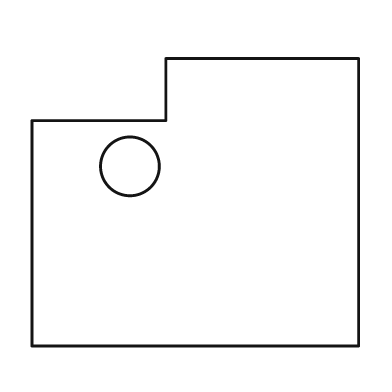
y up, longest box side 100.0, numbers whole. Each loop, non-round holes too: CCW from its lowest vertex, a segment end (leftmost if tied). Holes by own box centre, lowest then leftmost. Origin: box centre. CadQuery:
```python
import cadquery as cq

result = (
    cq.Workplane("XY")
    .moveTo(-50.0, -44.0)
    .lineTo(50.0, -44.0)
    .lineTo(50.0, 44.0)
    .lineTo(-9.0, 44.0)
    .lineTo(-9.0, 25.0)
    .lineTo(-50.0, 25.0)
    .close()
    .moveTo(-20.0, 11.0)
    .circle(9.0)
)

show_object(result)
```